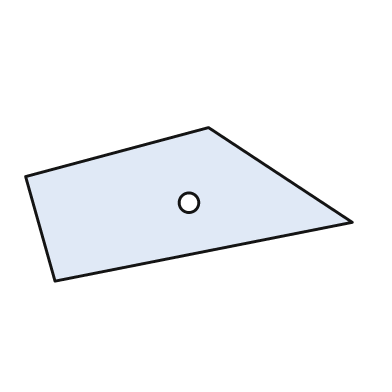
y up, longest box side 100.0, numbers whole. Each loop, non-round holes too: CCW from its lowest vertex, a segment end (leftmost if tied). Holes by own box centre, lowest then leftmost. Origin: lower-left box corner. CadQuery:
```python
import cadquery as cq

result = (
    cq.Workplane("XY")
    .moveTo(9.0, 0.0)
    .lineTo(100.0, 18.0)
    .lineTo(56.0, 47.0)
    .lineTo(0.0, 32.0)
    .close()
    .moveTo(50.0, 24.0)
    .circle(3.0)
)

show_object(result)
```